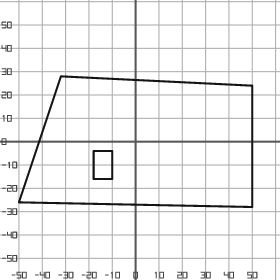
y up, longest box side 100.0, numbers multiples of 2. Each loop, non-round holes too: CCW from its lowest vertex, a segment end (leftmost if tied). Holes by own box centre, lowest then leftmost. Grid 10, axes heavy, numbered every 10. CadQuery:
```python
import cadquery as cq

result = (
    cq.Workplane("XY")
    .moveTo(50.0, -28.0)
    .lineTo(50.0, 24.0)
    .lineTo(-32.0, 28.0)
    .lineTo(-50.0, -26.0)
    .close()
    .moveTo(-18.0, -16.0)
    .lineTo(-10.0, -16.0)
    .lineTo(-10.0, -4.0)
    .lineTo(-18.0, -4.0)
    .close()
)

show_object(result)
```